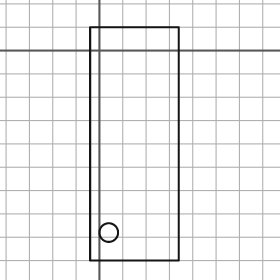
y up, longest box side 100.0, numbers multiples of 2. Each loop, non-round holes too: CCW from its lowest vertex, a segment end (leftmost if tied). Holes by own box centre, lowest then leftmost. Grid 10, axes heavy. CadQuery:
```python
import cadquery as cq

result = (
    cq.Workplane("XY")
    .moveTo(-4.0, -90.0)
    .lineTo(34.0, -90.0)
    .lineTo(34.0, 10.0)
    .lineTo(-4.0, 10.0)
    .close()
    .moveTo(4.0, -78.0)
    .circle(4.0)
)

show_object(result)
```